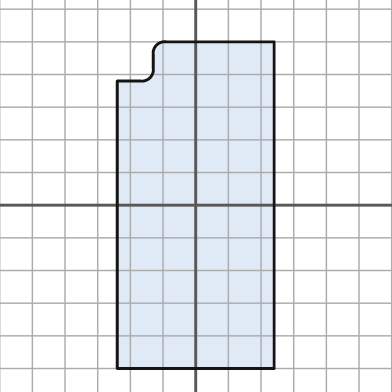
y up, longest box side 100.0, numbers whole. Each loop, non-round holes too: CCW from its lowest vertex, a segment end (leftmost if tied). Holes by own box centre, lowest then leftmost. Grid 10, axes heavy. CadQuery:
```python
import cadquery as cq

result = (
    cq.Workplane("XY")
    .moveTo(-24.0, -50.0)
    .lineTo(24.0, -50.0)
    .lineTo(24.0, 50.0)
    .lineTo(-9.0, 50.0)
    .threePointArc((-12.0, 49.0), (-13.0, 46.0))
    .lineTo(-13.0, 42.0)
    .threePointArc((-14.0, 39.0), (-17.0, 38.0))
    .lineTo(-24.0, 38.0)
    .close()
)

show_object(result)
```